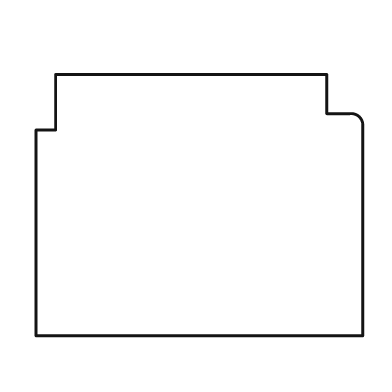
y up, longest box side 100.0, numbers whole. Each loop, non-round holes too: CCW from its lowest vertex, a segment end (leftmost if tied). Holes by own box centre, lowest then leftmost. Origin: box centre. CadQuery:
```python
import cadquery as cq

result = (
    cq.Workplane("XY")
    .moveTo(-50.0, -40.0)
    .lineTo(50.0, -40.0)
    .lineTo(50.0, 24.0)
    .threePointArc((49.0, 27.0), (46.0, 28.0))
    .lineTo(39.0, 28.0)
    .lineTo(39.0, 40.0)
    .lineTo(-44.0, 40.0)
    .lineTo(-44.0, 23.0)
    .lineTo(-50.0, 23.0)
    .close()
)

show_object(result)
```